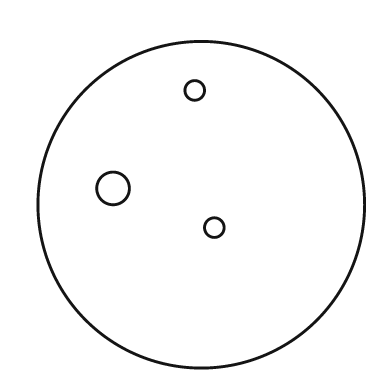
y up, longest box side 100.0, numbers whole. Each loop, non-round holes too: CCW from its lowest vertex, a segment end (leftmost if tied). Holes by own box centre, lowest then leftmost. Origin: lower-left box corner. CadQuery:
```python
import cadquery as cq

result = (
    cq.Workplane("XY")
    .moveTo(50.0, 50.0)
    .circle(50.0)
    .moveTo(54.0, 43.0)
    .circle(3.0)
    .moveTo(23.0, 55.0)
    .circle(5.0)
    .moveTo(48.0, 85.0)
    .circle(3.0)
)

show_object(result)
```